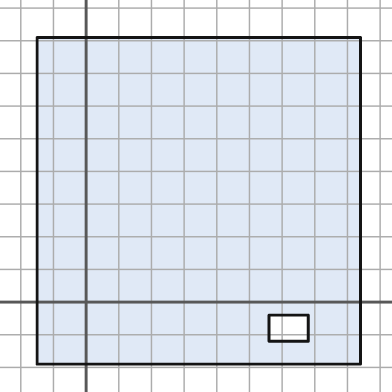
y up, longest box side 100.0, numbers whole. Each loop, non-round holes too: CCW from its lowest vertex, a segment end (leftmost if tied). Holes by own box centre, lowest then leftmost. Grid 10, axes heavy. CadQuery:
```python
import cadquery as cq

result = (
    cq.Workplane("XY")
    .moveTo(-15.0, -19.0)
    .lineTo(84.0, -19.0)
    .lineTo(84.0, 81.0)
    .lineTo(-15.0, 81.0)
    .close()
    .moveTo(56.0, -12.0)
    .lineTo(68.0, -12.0)
    .lineTo(68.0, -4.0)
    .lineTo(56.0, -4.0)
    .close()
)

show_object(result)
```